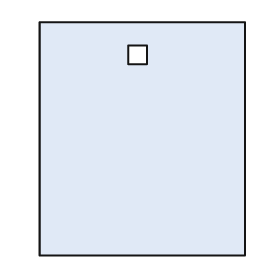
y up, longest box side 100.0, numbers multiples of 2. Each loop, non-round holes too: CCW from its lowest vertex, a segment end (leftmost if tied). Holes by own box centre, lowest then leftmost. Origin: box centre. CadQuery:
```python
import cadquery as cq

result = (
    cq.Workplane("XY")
    .moveTo(-44.0, -50.0)
    .lineTo(44.0, -50.0)
    .lineTo(44.0, 50.0)
    .lineTo(-44.0, 50.0)
    .close()
    .moveTo(-6.0, 32.0)
    .lineTo(2.0, 32.0)
    .lineTo(2.0, 40.0)
    .lineTo(-6.0, 40.0)
    .close()
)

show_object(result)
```